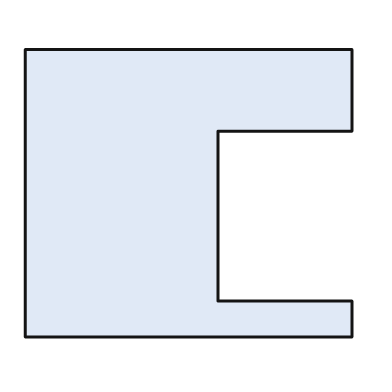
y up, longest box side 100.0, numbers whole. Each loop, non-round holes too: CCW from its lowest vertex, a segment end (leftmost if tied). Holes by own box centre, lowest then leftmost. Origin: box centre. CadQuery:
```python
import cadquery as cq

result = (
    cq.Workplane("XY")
    .moveTo(-50.0, -44.0)
    .lineTo(50.0, -44.0)
    .lineTo(50.0, -33.0)
    .lineTo(9.0, -33.0)
    .lineTo(9.0, 19.0)
    .lineTo(50.0, 19.0)
    .lineTo(50.0, 44.0)
    .lineTo(-50.0, 44.0)
    .close()
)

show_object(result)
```